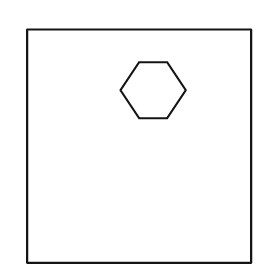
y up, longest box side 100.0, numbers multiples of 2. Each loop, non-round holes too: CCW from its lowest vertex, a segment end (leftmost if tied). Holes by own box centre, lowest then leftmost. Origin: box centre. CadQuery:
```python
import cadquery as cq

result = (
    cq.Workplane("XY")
    .moveTo(-48.0, -50.0)
    .lineTo(48.0, -50.0)
    .lineTo(48.0, 50.0)
    .lineTo(-48.0, 50.0)
    .close()
    .moveTo(0.0, 12.0)
    .lineTo(12.0, 12.0)
    .lineTo(20.0, 24.0)
    .lineTo(12.0, 36.0)
    .lineTo(0.0, 36.0)
    .lineTo(-8.0, 24.0)
    .close()
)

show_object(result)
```